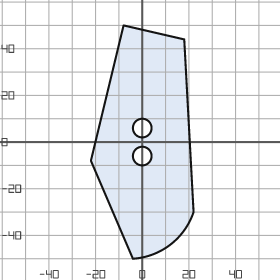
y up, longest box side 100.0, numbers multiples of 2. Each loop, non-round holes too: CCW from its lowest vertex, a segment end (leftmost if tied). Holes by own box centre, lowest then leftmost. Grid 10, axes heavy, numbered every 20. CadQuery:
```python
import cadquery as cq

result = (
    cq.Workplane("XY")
    .moveTo(-4.0, -50.0)
    .threePointArc((12.0, -44.0), (22.0, -30.0))
    .lineTo(18.0, 44.0)
    .lineTo(-8.0, 50.0)
    .lineTo(-22.0, -8.0)
    .close()
    .moveTo(0.0, -6.0)
    .circle(4.0)
    .moveTo(0.0, 6.0)
    .circle(4.0)
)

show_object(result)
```